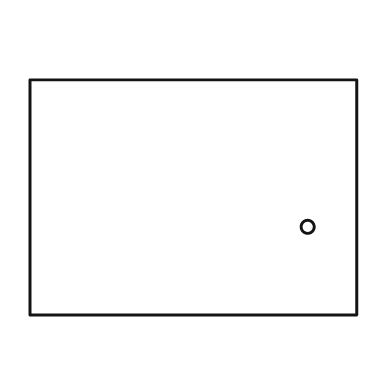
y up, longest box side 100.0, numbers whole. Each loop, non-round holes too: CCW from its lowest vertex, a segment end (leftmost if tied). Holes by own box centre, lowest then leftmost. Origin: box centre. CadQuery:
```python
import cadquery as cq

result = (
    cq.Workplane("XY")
    .moveTo(-50.0, -36.0)
    .lineTo(50.0, -36.0)
    .lineTo(50.0, 36.0)
    .lineTo(-50.0, 36.0)
    .close()
    .moveTo(35.0, -9.0)
    .circle(2.0)
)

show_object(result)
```